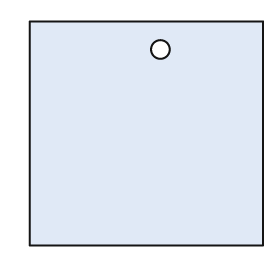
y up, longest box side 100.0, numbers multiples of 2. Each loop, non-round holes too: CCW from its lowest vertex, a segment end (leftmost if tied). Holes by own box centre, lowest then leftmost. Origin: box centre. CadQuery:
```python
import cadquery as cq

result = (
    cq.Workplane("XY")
    .moveTo(-50.0, -48.0)
    .lineTo(50.0, -48.0)
    .lineTo(50.0, 48.0)
    .lineTo(-50.0, 48.0)
    .close()
    .moveTo(6.0, 36.0)
    .circle(4.0)
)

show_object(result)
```